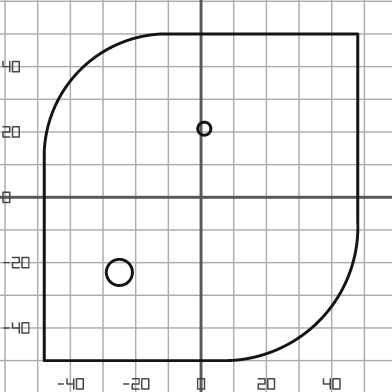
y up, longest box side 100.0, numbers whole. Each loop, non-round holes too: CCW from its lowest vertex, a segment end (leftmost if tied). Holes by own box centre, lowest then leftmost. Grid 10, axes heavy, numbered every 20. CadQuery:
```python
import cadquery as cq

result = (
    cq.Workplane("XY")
    .moveTo(-48.0, -50.0)
    .lineTo(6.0, -50.0)
    .threePointArc((36.0, -38.0), (48.0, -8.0))
    .lineTo(48.0, 50.0)
    .lineTo(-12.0, 50.0)
    .threePointArc((-37.0, 39.0), (-48.0, 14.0))
    .close()
    .moveTo(-25.0, -23.0)
    .circle(4.0)
    .moveTo(1.0, 21.0)
    .circle(2.0)
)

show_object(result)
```